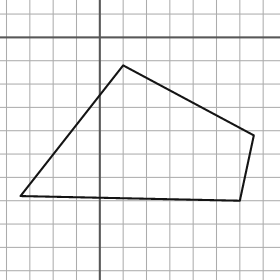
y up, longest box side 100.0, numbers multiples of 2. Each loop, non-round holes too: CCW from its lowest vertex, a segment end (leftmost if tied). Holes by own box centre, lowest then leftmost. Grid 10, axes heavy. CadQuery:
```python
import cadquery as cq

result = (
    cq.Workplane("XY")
    .moveTo(60.0, -70.0)
    .lineTo(66.0, -42.0)
    .lineTo(10.0, -12.0)
    .lineTo(-34.0, -68.0)
    .close()
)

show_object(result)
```